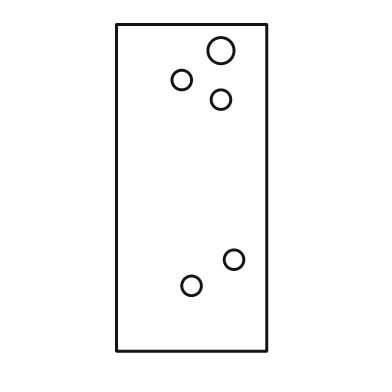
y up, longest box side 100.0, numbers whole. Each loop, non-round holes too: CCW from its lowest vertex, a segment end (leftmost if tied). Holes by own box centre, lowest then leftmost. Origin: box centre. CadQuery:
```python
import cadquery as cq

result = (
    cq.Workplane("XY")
    .moveTo(-23.0, -50.0)
    .lineTo(23.0, -50.0)
    .lineTo(23.0, 50.0)
    .lineTo(-23.0, 50.0)
    .close()
    .moveTo(0.0, -30.0)
    .circle(3.0)
    .moveTo(13.0, -22.0)
    .circle(3.0)
    .moveTo(9.0, 27.0)
    .circle(3.0)
    .moveTo(-3.0, 33.0)
    .circle(3.0)
    .moveTo(9.0, 42.0)
    .circle(4.0)
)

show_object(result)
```